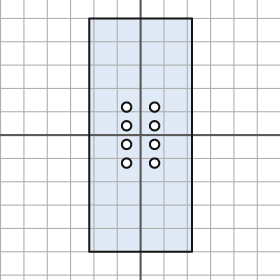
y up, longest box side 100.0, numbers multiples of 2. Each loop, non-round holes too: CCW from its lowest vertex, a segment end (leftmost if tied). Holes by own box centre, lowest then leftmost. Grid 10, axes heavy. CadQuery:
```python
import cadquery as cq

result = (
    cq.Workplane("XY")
    .moveTo(-22.0, -50.0)
    .lineTo(22.0, -50.0)
    .lineTo(22.0, 50.0)
    .lineTo(-22.0, 50.0)
    .close()
    .moveTo(-6.0, -12.0)
    .circle(2.0)
    .moveTo(6.0, -12.0)
    .circle(2.0)
    .moveTo(-6.0, -4.0)
    .circle(2.0)
    .moveTo(6.0, -4.0)
    .circle(2.0)
    .moveTo(-6.0, 4.0)
    .circle(2.0)
    .moveTo(6.0, 4.0)
    .circle(2.0)
    .moveTo(-6.0, 12.0)
    .circle(2.0)
    .moveTo(6.0, 12.0)
    .circle(2.0)
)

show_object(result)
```